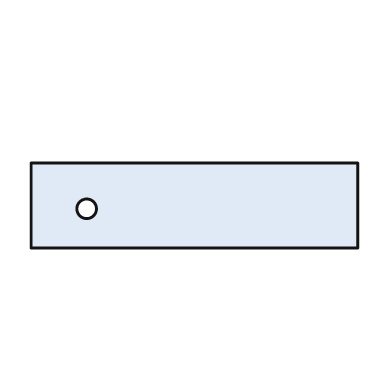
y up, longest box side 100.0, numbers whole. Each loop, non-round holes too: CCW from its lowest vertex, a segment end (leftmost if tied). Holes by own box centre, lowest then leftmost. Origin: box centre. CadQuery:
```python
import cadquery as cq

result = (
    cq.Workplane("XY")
    .moveTo(-50.0, -13.0)
    .lineTo(50.0, -13.0)
    .lineTo(50.0, 13.0)
    .lineTo(-50.0, 13.0)
    .close()
    .moveTo(-33.0, -1.0)
    .circle(3.0)
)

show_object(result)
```